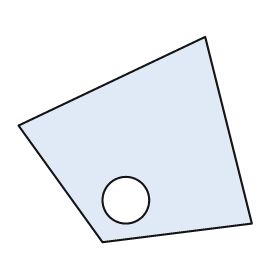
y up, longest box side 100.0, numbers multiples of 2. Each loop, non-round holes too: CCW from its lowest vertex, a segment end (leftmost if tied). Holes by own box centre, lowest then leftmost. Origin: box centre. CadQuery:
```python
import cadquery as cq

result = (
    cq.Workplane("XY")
    .moveTo(-14.0, -44.0)
    .lineTo(50.0, -36.0)
    .lineTo(30.0, 44.0)
    .lineTo(-50.0, 6.0)
    .close()
    .moveTo(-4.0, -26.0)
    .circle(10.0)
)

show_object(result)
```